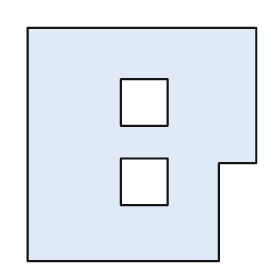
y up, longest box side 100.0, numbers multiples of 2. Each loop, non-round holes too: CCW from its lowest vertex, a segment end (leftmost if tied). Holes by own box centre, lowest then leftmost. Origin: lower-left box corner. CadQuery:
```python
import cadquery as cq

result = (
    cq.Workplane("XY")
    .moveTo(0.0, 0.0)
    .lineTo(82.0, 0.0)
    .lineTo(82.0, 42.0)
    .lineTo(98.0, 42.0)
    .lineTo(98.0, 100.0)
    .lineTo(0.0, 100.0)
    .close()
    .moveTo(40.0, 24.0)
    .lineTo(60.0, 24.0)
    .lineTo(60.0, 44.0)
    .lineTo(40.0, 44.0)
    .close()
    .moveTo(40.0, 58.0)
    .lineTo(60.0, 58.0)
    .lineTo(60.0, 78.0)
    .lineTo(40.0, 78.0)
    .close()
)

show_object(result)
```